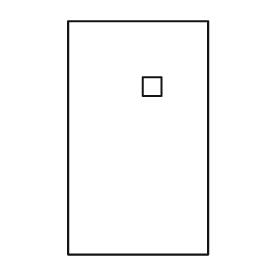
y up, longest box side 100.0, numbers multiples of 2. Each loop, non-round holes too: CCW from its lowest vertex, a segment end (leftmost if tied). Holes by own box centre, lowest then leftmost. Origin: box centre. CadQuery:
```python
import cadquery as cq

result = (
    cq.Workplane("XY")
    .moveTo(-30.0, -50.0)
    .lineTo(30.0, -50.0)
    .lineTo(30.0, 50.0)
    .lineTo(-30.0, 50.0)
    .close()
    .moveTo(2.0, 18.0)
    .lineTo(10.0, 18.0)
    .lineTo(10.0, 26.0)
    .lineTo(2.0, 26.0)
    .close()
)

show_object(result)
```